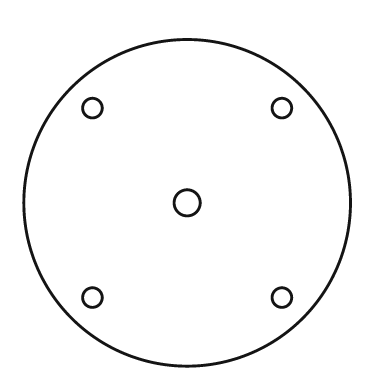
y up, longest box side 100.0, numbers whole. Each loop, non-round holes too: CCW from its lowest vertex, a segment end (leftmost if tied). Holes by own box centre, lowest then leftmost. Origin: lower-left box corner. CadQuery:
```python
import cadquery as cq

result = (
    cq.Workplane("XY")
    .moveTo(50.0, 50.0)
    .circle(50.0)
    .moveTo(21.0, 21.0)
    .circle(3.0)
    .moveTo(79.0, 21.0)
    .circle(3.0)
    .moveTo(50.0, 50.0)
    .circle(4.0)
    .moveTo(21.0, 79.0)
    .circle(3.0)
    .moveTo(79.0, 79.0)
    .circle(3.0)
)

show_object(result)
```